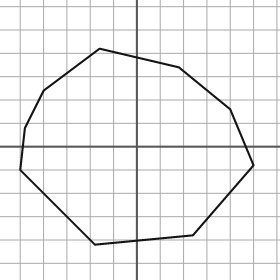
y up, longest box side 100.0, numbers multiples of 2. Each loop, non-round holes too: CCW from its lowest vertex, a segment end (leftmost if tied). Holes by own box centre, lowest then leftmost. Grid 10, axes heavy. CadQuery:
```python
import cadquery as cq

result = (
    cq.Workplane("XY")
    .moveTo(-18.0, -42.0)
    .lineTo(24.0, -38.0)
    .lineTo(50.0, -8.0)
    .lineTo(40.0, 16.0)
    .lineTo(18.0, 34.0)
    .lineTo(-16.0, 42.0)
    .lineTo(-40.0, 24.0)
    .lineTo(-48.0, 8.0)
    .lineTo(-50.0, -10.0)
    .close()
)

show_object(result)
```